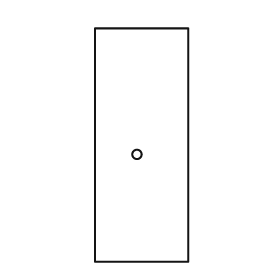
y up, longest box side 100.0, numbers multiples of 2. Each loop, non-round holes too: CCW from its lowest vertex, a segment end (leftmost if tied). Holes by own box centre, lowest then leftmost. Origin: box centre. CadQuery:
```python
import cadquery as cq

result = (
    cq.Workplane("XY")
    .moveTo(-20.0, -50.0)
    .lineTo(20.0, -50.0)
    .lineTo(20.0, 50.0)
    .lineTo(-20.0, 50.0)
    .close()
    .moveTo(-2.0, -4.0)
    .circle(2.0)
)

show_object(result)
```